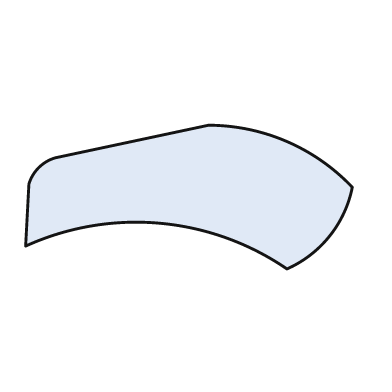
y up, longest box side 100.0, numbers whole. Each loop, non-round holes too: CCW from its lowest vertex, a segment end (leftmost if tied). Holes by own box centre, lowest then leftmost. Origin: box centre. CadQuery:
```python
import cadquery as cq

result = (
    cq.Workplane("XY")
    .moveTo(30.0, -22.0)
    .threePointArc((43.0, -12.0), (50.0, 3.0))
    .threePointArc((30.0, 17.0), (6.0, 22.0))
    .lineTo(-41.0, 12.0)
    .threePointArc((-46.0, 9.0), (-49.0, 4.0))
    .lineTo(-50.0, -15.0)
    .threePointArc((-9.0, -8.0), (30.0, -22.0))
    .close()
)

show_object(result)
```